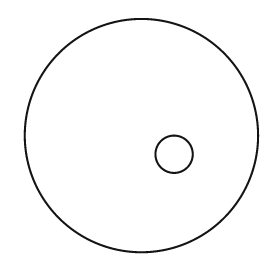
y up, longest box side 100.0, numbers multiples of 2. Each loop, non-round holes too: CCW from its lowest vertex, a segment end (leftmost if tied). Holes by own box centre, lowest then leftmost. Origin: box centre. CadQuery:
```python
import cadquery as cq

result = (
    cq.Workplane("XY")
    .moveTo(0.0, 0.0)
    .circle(50.0)
    .moveTo(14.0, -8.0)
    .circle(8.0)
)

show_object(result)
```